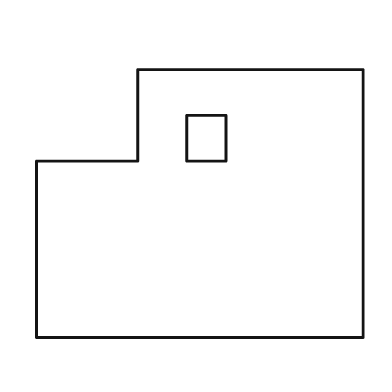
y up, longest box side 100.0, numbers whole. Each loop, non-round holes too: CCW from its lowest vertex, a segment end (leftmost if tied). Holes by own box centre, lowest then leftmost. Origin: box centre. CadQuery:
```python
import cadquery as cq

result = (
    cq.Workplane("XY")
    .moveTo(-50.0, -41.0)
    .lineTo(50.0, -41.0)
    .lineTo(50.0, 41.0)
    .lineTo(-19.0, 41.0)
    .lineTo(-19.0, 13.0)
    .lineTo(-50.0, 13.0)
    .close()
    .moveTo(-4.0, 13.0)
    .lineTo(8.0, 13.0)
    .lineTo(8.0, 27.0)
    .lineTo(-4.0, 27.0)
    .close()
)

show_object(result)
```